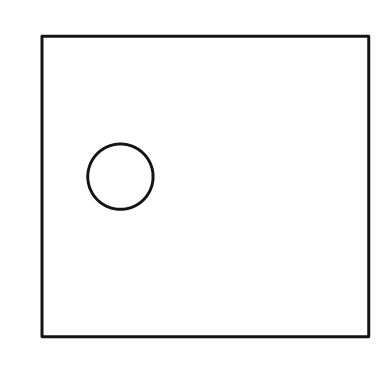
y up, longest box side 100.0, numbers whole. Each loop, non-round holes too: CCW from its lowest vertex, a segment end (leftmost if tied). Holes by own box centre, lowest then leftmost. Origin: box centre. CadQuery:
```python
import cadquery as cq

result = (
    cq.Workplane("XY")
    .moveTo(-50.0, -46.0)
    .lineTo(50.0, -46.0)
    .lineTo(50.0, 46.0)
    .lineTo(-50.0, 46.0)
    .close()
    .moveTo(-26.0, 3.0)
    .circle(10.0)
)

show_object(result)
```